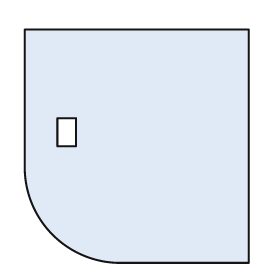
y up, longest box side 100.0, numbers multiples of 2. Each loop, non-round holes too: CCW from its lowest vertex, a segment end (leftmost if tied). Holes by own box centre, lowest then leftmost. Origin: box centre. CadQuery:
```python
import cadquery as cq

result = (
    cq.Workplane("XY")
    .moveTo(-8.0, -50.0)
    .lineTo(48.0, -50.0)
    .lineTo(48.0, 50.0)
    .lineTo(-48.0, 50.0)
    .lineTo(-48.0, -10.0)
    .threePointArc((-36.0, -38.0), (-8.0, -50.0))
    .close()
    .moveTo(-34.0, 0.0)
    .lineTo(-26.0, 0.0)
    .lineTo(-26.0, 12.0)
    .lineTo(-34.0, 12.0)
    .close()
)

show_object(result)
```